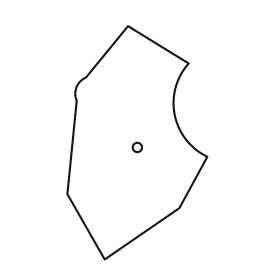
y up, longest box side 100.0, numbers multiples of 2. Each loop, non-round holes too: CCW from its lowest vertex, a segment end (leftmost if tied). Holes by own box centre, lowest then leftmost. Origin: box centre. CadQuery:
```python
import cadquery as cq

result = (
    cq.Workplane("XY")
    .moveTo(-14.0, -50.0)
    .lineTo(18.0, -28.0)
    .lineTo(30.0, -6.0)
    .threePointArc((16.0, 12.0), (22.0, 34.0))
    .lineTo(-4.0, 50.0)
    .lineTo(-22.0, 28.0)
    .threePointArc((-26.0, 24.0), (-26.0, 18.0))
    .lineTo(-30.0, -22.0)
    .close()
    .moveTo(0.0, -2.0)
    .circle(2.0)
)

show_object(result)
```